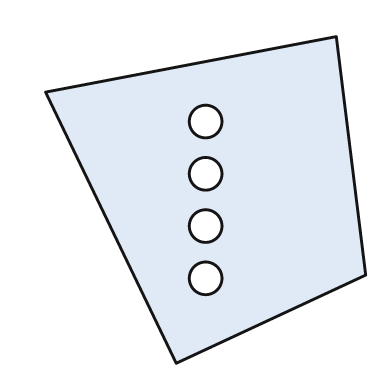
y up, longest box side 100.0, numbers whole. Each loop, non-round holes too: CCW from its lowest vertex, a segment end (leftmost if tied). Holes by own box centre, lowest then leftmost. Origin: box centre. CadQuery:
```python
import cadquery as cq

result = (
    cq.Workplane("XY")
    .moveTo(-9.0, -50.0)
    .lineTo(49.0, -23.0)
    .lineTo(40.0, 50.0)
    .lineTo(-49.0, 33.0)
    .close()
    .moveTo(0.0, -24.0)
    .circle(5.0)
    .moveTo(0.0, -8.0)
    .circle(5.0)
    .moveTo(0.0, 8.0)
    .circle(5.0)
    .moveTo(0.0, 24.0)
    .circle(5.0)
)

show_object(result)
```